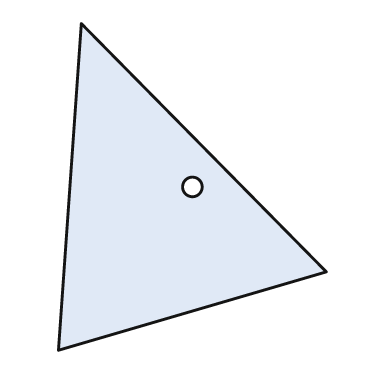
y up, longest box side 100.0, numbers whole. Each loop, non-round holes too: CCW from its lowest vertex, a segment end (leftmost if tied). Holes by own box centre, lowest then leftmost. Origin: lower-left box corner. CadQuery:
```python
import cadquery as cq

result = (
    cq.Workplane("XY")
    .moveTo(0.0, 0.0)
    .lineTo(82.0, 24.0)
    .lineTo(7.0, 100.0)
    .close()
    .moveTo(41.0, 50.0)
    .circle(3.0)
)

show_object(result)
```